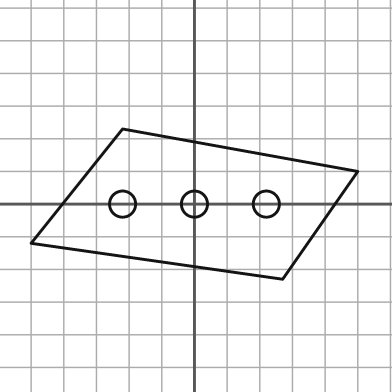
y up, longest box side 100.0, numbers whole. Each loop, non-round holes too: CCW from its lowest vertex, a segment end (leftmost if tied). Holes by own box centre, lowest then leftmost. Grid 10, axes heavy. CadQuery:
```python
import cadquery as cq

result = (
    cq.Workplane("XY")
    .moveTo(27.0, -23.0)
    .lineTo(50.0, 10.0)
    .lineTo(-22.0, 23.0)
    .lineTo(-50.0, -12.0)
    .close()
    .moveTo(-22.0, 0.0)
    .circle(4.0)
    .moveTo(0.0, 0.0)
    .circle(4.0)
    .moveTo(22.0, 0.0)
    .circle(4.0)
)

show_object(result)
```